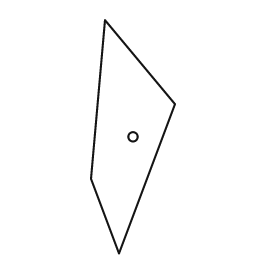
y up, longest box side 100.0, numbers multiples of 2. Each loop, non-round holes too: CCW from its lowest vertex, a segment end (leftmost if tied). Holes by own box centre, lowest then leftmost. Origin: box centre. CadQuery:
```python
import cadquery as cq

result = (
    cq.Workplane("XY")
    .moveTo(-6.0, -50.0)
    .lineTo(18.0, 14.0)
    .lineTo(-12.0, 50.0)
    .lineTo(-18.0, -18.0)
    .close()
    .moveTo(0.0, 0.0)
    .circle(2.0)
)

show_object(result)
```